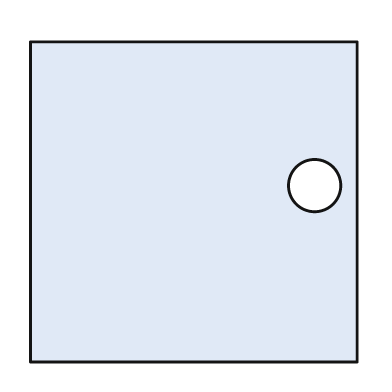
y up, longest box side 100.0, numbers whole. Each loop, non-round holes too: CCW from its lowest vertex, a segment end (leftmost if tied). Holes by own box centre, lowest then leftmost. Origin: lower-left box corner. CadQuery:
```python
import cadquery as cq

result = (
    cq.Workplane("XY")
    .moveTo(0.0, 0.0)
    .lineTo(100.0, 0.0)
    .lineTo(100.0, 98.0)
    .lineTo(0.0, 98.0)
    .close()
    .moveTo(87.0, 54.0)
    .circle(8.0)
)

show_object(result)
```